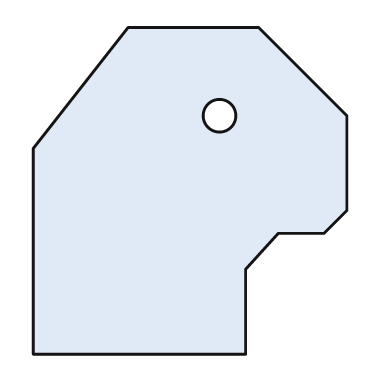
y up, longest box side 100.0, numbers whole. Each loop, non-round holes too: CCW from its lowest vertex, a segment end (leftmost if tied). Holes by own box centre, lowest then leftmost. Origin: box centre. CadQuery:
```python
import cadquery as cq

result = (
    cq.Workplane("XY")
    .moveTo(-48.0, -50.0)
    .lineTo(17.0, -50.0)
    .lineTo(17.0, -24.0)
    .lineTo(27.0, -13.0)
    .lineTo(41.0, -13.0)
    .lineTo(48.0, -6.0)
    .lineTo(48.0, 23.0)
    .lineTo(21.0, 50.0)
    .lineTo(-19.0, 50.0)
    .lineTo(-48.0, 13.0)
    .close()
    .moveTo(9.0, 23.0)
    .circle(5.0)
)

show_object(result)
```